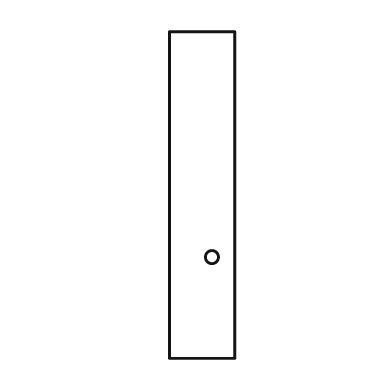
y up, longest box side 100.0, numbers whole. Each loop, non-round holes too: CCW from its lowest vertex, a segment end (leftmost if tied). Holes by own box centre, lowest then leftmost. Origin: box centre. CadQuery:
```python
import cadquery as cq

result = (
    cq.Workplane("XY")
    .moveTo(-10.0, -50.0)
    .lineTo(10.0, -50.0)
    .lineTo(10.0, 50.0)
    .lineTo(-10.0, 50.0)
    .close()
    .moveTo(3.0, -19.0)
    .circle(2.0)
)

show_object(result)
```